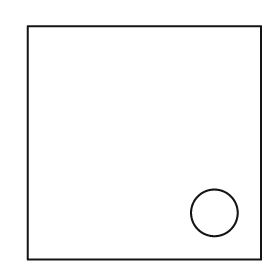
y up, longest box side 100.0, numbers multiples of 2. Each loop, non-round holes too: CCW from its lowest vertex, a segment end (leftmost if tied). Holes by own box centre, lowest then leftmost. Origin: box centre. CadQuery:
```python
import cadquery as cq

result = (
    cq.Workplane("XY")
    .moveTo(-50.0, -50.0)
    .lineTo(50.0, -50.0)
    .lineTo(50.0, 50.0)
    .lineTo(-50.0, 50.0)
    .close()
    .moveTo(30.0, -30.0)
    .circle(10.0)
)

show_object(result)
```